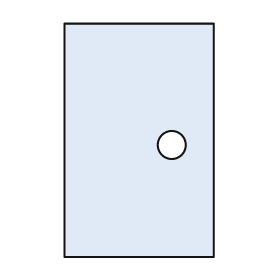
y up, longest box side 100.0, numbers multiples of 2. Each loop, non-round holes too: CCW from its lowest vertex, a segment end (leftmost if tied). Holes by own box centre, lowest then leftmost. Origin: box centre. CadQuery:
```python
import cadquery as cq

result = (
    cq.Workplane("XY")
    .moveTo(-32.0, -50.0)
    .lineTo(32.0, -50.0)
    .lineTo(32.0, 50.0)
    .lineTo(-32.0, 50.0)
    .close()
    .moveTo(14.0, -2.0)
    .circle(6.0)
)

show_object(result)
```